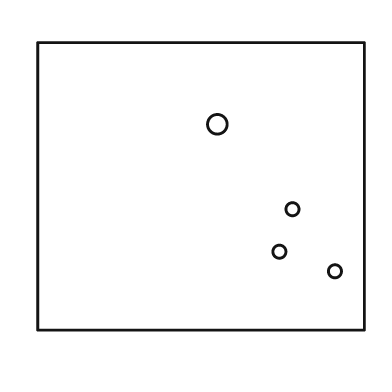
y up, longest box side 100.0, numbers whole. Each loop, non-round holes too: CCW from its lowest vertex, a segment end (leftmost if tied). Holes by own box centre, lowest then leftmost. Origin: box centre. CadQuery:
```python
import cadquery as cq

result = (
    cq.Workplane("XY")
    .moveTo(-50.0, -44.0)
    .lineTo(50.0, -44.0)
    .lineTo(50.0, 44.0)
    .lineTo(-50.0, 44.0)
    .close()
    .moveTo(41.0, -26.0)
    .circle(2.0)
    .moveTo(24.0, -20.0)
    .circle(2.0)
    .moveTo(28.0, -7.0)
    .circle(2.0)
    .moveTo(5.0, 19.0)
    .circle(3.0)
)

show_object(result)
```